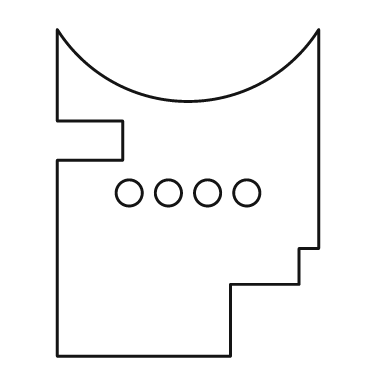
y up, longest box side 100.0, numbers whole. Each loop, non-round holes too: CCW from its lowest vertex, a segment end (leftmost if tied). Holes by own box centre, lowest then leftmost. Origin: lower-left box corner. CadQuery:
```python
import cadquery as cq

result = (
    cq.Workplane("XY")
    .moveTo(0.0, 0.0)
    .lineTo(53.0, 0.0)
    .lineTo(53.0, 22.0)
    .lineTo(74.0, 22.0)
    .lineTo(74.0, 33.0)
    .lineTo(80.0, 33.0)
    .lineTo(80.0, 100.0)
    .threePointArc((40.0, 78.0), (0.0, 100.0))
    .lineTo(0.0, 72.0)
    .lineTo(20.0, 72.0)
    .lineTo(20.0, 60.0)
    .lineTo(0.0, 60.0)
    .close()
    .moveTo(22.0, 50.0)
    .circle(4.0)
    .moveTo(34.0, 50.0)
    .circle(4.0)
    .moveTo(46.0, 50.0)
    .circle(4.0)
    .moveTo(58.0, 50.0)
    .circle(4.0)
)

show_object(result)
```